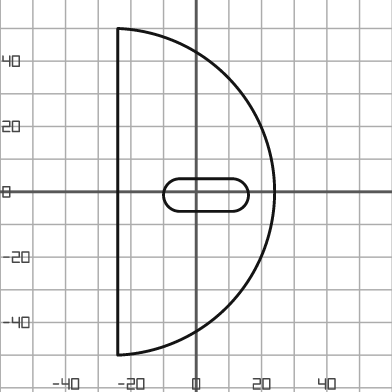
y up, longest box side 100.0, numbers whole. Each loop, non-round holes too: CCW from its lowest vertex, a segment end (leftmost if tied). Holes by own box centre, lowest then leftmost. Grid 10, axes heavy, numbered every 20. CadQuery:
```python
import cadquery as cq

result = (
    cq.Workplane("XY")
    .moveTo(-24.0, -50.0)
    .threePointArc((24.0, 0.0), (-24.0, 50.0))
    .close()
    .moveTo(-5.0, -6.0)
    .lineTo(11.0, -6.0)
    .threePointArc((16.0, -1.0), (11.0, 4.0))
    .lineTo(-5.0, 4.0)
    .threePointArc((-10.0, -1.0), (-5.0, -6.0))
    .close()
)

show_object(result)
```